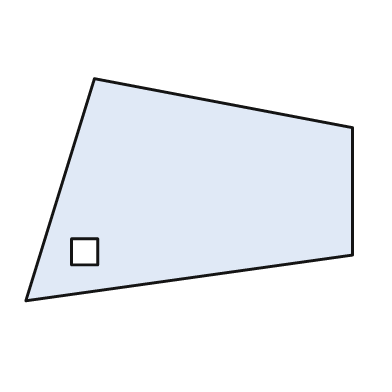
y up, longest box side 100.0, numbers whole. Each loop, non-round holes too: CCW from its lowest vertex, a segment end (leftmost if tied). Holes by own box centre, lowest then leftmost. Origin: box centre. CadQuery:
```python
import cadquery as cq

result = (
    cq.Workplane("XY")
    .moveTo(-50.0, -34.0)
    .lineTo(50.0, -20.0)
    .lineTo(50.0, 19.0)
    .lineTo(-29.0, 34.0)
    .close()
    .moveTo(-36.0, -23.0)
    .lineTo(-28.0, -23.0)
    .lineTo(-28.0, -15.0)
    .lineTo(-36.0, -15.0)
    .close()
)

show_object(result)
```